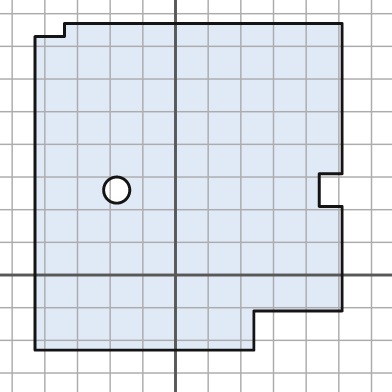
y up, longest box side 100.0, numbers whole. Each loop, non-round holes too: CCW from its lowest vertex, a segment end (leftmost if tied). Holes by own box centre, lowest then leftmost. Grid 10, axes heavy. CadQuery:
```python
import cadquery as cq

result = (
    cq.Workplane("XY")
    .moveTo(-43.0, -23.0)
    .lineTo(24.0, -23.0)
    .lineTo(24.0, -11.0)
    .lineTo(51.0, -11.0)
    .lineTo(51.0, 21.0)
    .lineTo(44.0, 21.0)
    .lineTo(44.0, 31.0)
    .lineTo(51.0, 31.0)
    .lineTo(51.0, 77.0)
    .lineTo(-34.0, 77.0)
    .lineTo(-34.0, 73.0)
    .lineTo(-43.0, 73.0)
    .close()
    .moveTo(-18.0, 26.0)
    .circle(4.0)
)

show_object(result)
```